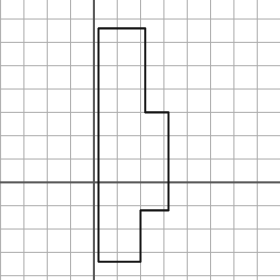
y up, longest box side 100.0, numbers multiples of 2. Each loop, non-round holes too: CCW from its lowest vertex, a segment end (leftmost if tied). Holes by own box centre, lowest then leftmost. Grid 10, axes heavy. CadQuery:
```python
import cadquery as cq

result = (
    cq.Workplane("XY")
    .moveTo(2.0, -34.0)
    .lineTo(20.0, -34.0)
    .lineTo(20.0, -12.0)
    .lineTo(32.0, -12.0)
    .lineTo(32.0, 30.0)
    .lineTo(22.0, 30.0)
    .lineTo(22.0, 66.0)
    .lineTo(2.0, 66.0)
    .close()
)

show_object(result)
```